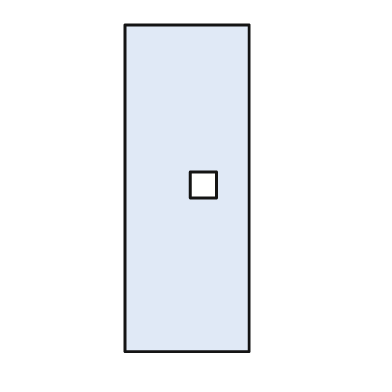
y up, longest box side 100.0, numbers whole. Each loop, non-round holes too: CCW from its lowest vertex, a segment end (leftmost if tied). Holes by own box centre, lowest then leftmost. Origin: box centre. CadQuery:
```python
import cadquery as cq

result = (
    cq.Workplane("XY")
    .moveTo(-19.0, -50.0)
    .lineTo(19.0, -50.0)
    .lineTo(19.0, 50.0)
    .lineTo(-19.0, 50.0)
    .close()
    .moveTo(1.0, -3.0)
    .lineTo(9.0, -3.0)
    .lineTo(9.0, 5.0)
    .lineTo(1.0, 5.0)
    .close()
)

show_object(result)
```